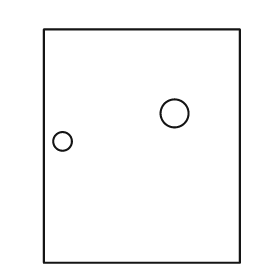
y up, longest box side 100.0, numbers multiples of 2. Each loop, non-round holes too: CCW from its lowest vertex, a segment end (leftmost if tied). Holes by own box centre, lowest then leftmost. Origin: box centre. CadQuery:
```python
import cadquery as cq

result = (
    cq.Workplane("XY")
    .moveTo(-42.0, -50.0)
    .lineTo(42.0, -50.0)
    .lineTo(42.0, 50.0)
    .lineTo(-42.0, 50.0)
    .close()
    .moveTo(-34.0, 2.0)
    .circle(4.0)
    .moveTo(14.0, 14.0)
    .circle(6.0)
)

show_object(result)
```